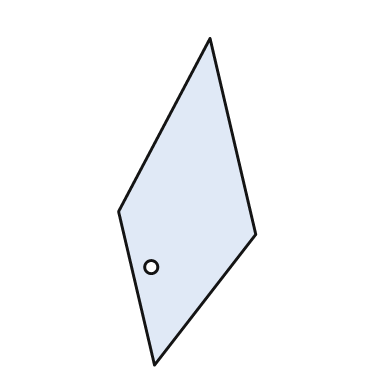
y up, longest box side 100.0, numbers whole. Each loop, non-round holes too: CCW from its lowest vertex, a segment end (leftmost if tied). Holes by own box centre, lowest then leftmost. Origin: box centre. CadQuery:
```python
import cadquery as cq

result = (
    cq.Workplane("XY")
    .moveTo(-10.0, -50.0)
    .lineTo(21.0, -10.0)
    .lineTo(7.0, 50.0)
    .lineTo(-21.0, -3.0)
    .close()
    .moveTo(-11.0, -20.0)
    .circle(2.0)
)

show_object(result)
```